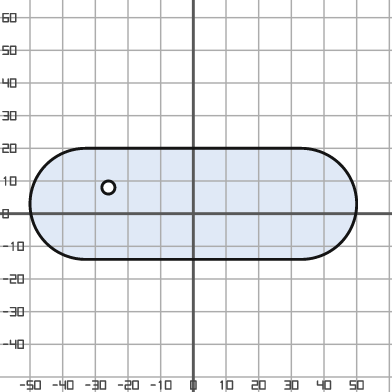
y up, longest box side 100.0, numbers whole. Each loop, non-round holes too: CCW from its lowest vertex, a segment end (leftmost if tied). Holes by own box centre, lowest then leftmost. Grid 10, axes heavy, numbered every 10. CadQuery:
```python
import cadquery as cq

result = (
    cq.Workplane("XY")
    .moveTo(-33.0, -14.0)
    .lineTo(33.0, -14.0)
    .threePointArc((50.0, 3.0), (33.0, 20.0))
    .lineTo(-33.0, 20.0)
    .threePointArc((-50.0, 3.0), (-33.0, -14.0))
    .close()
    .moveTo(-26.0, 8.0)
    .circle(2.0)
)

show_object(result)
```